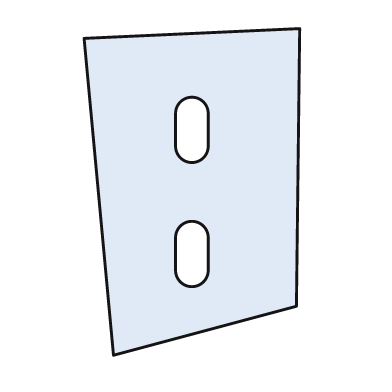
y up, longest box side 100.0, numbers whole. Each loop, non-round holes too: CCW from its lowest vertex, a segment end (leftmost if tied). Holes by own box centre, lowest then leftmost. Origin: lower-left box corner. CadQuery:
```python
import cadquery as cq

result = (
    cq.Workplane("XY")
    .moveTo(9.0, 0.0)
    .lineTo(65.0, 15.0)
    .lineTo(66.0, 100.0)
    .lineTo(0.0, 97.0)
    .close()
    .moveTo(28.0, 26.0)
    .threePointArc((33.0, 21.0), (38.0, 26.0))
    .lineTo(38.0, 36.0)
    .threePointArc((33.0, 41.0), (28.0, 36.0))
    .close()
    .moveTo(28.0, 64.0)
    .threePointArc((33.0, 59.0), (38.0, 64.0))
    .lineTo(38.0, 74.0)
    .threePointArc((33.0, 79.0), (28.0, 74.0))
    .close()
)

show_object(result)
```